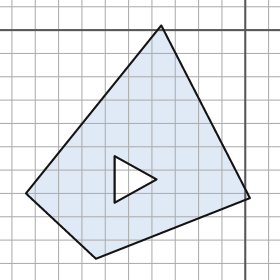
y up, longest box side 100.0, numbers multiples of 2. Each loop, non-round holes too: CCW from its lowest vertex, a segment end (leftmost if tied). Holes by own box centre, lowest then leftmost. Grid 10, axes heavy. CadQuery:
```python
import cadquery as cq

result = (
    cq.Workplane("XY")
    .moveTo(-64.0, -98.0)
    .lineTo(2.0, -72.0)
    .lineTo(-36.0, 2.0)
    .lineTo(-94.0, -70.0)
    .close()
    .moveTo(-56.0, -74.0)
    .lineTo(-38.0, -64.0)
    .lineTo(-56.0, -54.0)
    .close()
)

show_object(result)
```